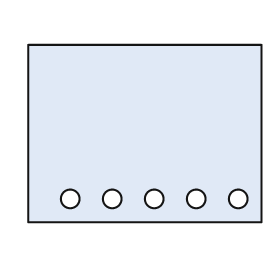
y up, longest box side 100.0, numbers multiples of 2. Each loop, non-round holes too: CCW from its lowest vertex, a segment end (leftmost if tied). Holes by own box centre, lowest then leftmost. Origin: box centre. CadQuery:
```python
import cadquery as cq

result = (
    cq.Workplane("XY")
    .moveTo(-50.0, -38.0)
    .lineTo(50.0, -38.0)
    .lineTo(50.0, 38.0)
    .lineTo(-50.0, 38.0)
    .close()
    .moveTo(-32.0, -28.0)
    .circle(4.0)
    .moveTo(-14.0, -28.0)
    .circle(4.0)
    .moveTo(4.0, -28.0)
    .circle(4.0)
    .moveTo(22.0, -28.0)
    .circle(4.0)
    .moveTo(40.0, -28.0)
    .circle(4.0)
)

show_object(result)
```